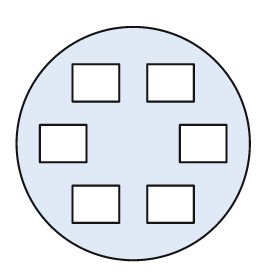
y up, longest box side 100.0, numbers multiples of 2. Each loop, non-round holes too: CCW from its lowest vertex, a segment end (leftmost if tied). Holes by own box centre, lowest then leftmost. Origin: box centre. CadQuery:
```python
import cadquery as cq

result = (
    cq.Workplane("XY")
    .moveTo(0.0, 0.0)
    .circle(50.0)
    .moveTo(-26.0, -34.0)
    .lineTo(-6.0, -34.0)
    .lineTo(-6.0, -18.0)
    .lineTo(-26.0, -18.0)
    .close()
    .moveTo(6.0, -34.0)
    .lineTo(26.0, -34.0)
    .lineTo(26.0, -18.0)
    .lineTo(6.0, -18.0)
    .close()
    .moveTo(-40.0, -8.0)
    .lineTo(-20.0, -8.0)
    .lineTo(-20.0, 8.0)
    .lineTo(-40.0, 8.0)
    .close()
    .moveTo(20.0, -8.0)
    .lineTo(40.0, -8.0)
    .lineTo(40.0, 8.0)
    .lineTo(20.0, 8.0)
    .close()
    .moveTo(-26.0, 18.0)
    .lineTo(-6.0, 18.0)
    .lineTo(-6.0, 34.0)
    .lineTo(-26.0, 34.0)
    .close()
    .moveTo(6.0, 18.0)
    .lineTo(26.0, 18.0)
    .lineTo(26.0, 34.0)
    .lineTo(6.0, 34.0)
    .close()
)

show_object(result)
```